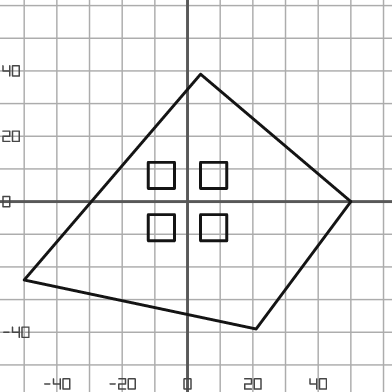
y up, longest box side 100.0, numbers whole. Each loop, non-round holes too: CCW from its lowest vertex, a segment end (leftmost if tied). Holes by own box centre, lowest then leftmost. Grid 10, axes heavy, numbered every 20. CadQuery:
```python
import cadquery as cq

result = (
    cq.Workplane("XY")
    .moveTo(21.0, -39.0)
    .lineTo(50.0, 0.0)
    .lineTo(4.0, 39.0)
    .lineTo(-50.0, -24.0)
    .close()
    .moveTo(-12.0, -12.0)
    .lineTo(-4.0, -12.0)
    .lineTo(-4.0, -4.0)
    .lineTo(-12.0, -4.0)
    .close()
    .moveTo(4.0, -12.0)
    .lineTo(12.0, -12.0)
    .lineTo(12.0, -4.0)
    .lineTo(4.0, -4.0)
    .close()
    .moveTo(-12.0, 4.0)
    .lineTo(-4.0, 4.0)
    .lineTo(-4.0, 12.0)
    .lineTo(-12.0, 12.0)
    .close()
    .moveTo(4.0, 4.0)
    .lineTo(12.0, 4.0)
    .lineTo(12.0, 12.0)
    .lineTo(4.0, 12.0)
    .close()
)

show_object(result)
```